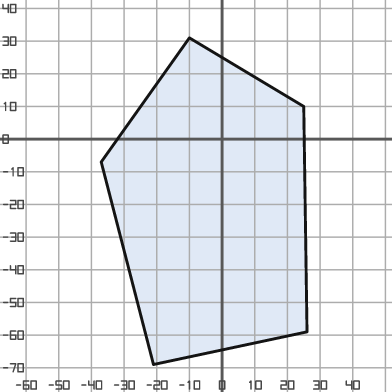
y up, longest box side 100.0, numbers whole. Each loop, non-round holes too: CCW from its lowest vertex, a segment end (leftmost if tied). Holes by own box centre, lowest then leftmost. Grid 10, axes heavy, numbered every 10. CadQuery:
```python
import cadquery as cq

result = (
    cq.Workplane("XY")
    .moveTo(-21.0, -69.0)
    .lineTo(26.0, -59.0)
    .lineTo(25.0, 10.0)
    .lineTo(-10.0, 31.0)
    .lineTo(-37.0, -7.0)
    .close()
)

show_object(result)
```